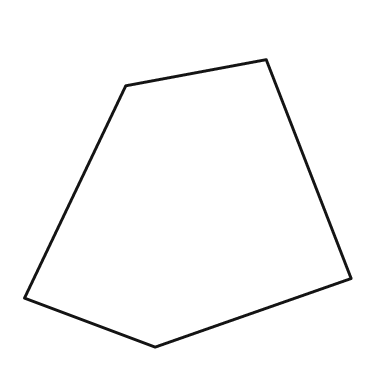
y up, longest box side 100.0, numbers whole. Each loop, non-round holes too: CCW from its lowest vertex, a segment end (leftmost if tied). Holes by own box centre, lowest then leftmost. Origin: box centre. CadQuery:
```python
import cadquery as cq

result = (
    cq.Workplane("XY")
    .moveTo(-10.0, -44.0)
    .lineTo(50.0, -23.0)
    .lineTo(24.0, 44.0)
    .lineTo(-19.0, 36.0)
    .lineTo(-50.0, -29.0)
    .close()
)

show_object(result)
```